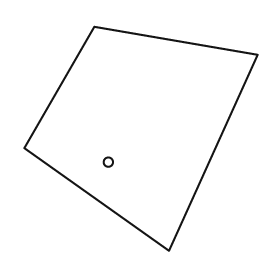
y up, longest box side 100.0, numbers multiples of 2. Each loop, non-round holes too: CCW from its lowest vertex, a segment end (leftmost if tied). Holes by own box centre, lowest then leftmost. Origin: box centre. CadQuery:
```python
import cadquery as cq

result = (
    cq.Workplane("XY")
    .moveTo(12.0, -48.0)
    .lineTo(50.0, 36.0)
    .lineTo(-20.0, 48.0)
    .lineTo(-50.0, -4.0)
    .close()
    .moveTo(-14.0, -10.0)
    .circle(2.0)
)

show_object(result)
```